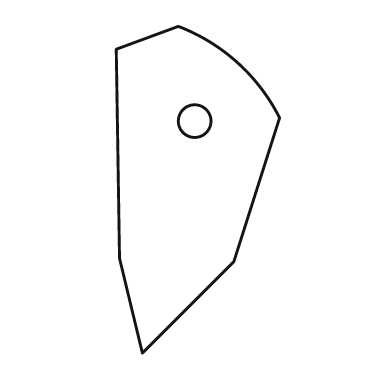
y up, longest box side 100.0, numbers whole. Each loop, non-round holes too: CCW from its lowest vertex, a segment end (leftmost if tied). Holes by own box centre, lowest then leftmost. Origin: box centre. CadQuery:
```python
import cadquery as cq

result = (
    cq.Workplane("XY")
    .moveTo(-17.0, -50.0)
    .lineTo(11.0, -22.0)
    .lineTo(25.0, 22.0)
    .threePointArc((12.0, 39.0), (-6.0, 50.0))
    .lineTo(-25.0, 43.0)
    .lineTo(-24.0, -21.0)
    .close()
    .moveTo(-1.0, 21.0)
    .circle(5.0)
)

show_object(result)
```